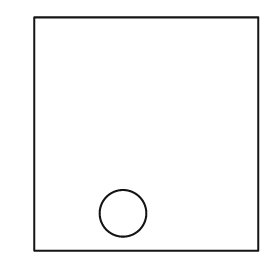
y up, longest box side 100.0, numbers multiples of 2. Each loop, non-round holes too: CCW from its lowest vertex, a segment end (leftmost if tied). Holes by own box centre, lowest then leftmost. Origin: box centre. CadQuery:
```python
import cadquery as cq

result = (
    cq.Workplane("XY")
    .moveTo(-48.0, -50.0)
    .lineTo(48.0, -50.0)
    .lineTo(48.0, 50.0)
    .lineTo(-48.0, 50.0)
    .close()
    .moveTo(-10.0, -34.0)
    .circle(10.0)
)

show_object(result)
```